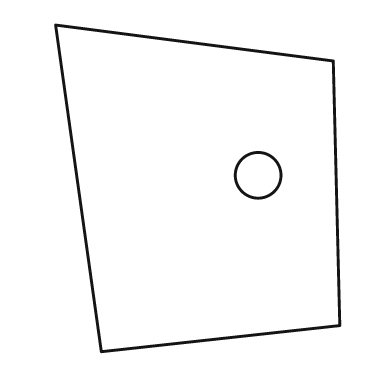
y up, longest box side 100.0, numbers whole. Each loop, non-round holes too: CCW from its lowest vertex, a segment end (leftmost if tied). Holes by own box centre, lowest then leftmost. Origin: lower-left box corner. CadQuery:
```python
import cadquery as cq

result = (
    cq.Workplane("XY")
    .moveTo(14.0, 0.0)
    .lineTo(87.0, 8.0)
    .lineTo(85.0, 89.0)
    .lineTo(0.0, 100.0)
    .close()
    .moveTo(62.0, 54.0)
    .circle(7.0)
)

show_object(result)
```